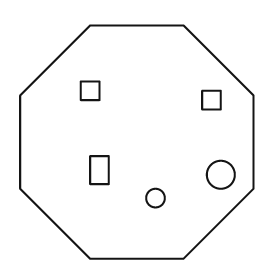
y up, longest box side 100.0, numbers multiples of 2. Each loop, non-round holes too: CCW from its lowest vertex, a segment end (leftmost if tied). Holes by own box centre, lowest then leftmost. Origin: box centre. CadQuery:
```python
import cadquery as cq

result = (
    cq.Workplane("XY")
    .moveTo(-20.0, -50.0)
    .lineTo(20.0, -50.0)
    .lineTo(50.0, -20.0)
    .lineTo(50.0, 20.0)
    .lineTo(20.0, 50.0)
    .lineTo(-20.0, 50.0)
    .lineTo(-50.0, 20.0)
    .lineTo(-50.0, -20.0)
    .close()
    .moveTo(8.0, -24.0)
    .circle(4.0)
    .moveTo(36.0, -14.0)
    .circle(6.0)
    .moveTo(-20.0, -18.0)
    .lineTo(-12.0, -18.0)
    .lineTo(-12.0, -6.0)
    .lineTo(-20.0, -6.0)
    .close()
    .moveTo(28.0, 14.0)
    .lineTo(36.0, 14.0)
    .lineTo(36.0, 22.0)
    .lineTo(28.0, 22.0)
    .close()
    .moveTo(-24.0, 18.0)
    .lineTo(-16.0, 18.0)
    .lineTo(-16.0, 26.0)
    .lineTo(-24.0, 26.0)
    .close()
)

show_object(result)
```